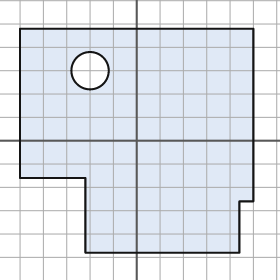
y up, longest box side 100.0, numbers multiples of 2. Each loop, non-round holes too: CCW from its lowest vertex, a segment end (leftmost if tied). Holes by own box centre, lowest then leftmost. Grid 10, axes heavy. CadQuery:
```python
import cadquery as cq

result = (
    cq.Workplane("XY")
    .moveTo(-22.0, -48.0)
    .lineTo(44.0, -48.0)
    .lineTo(44.0, -26.0)
    .lineTo(50.0, -26.0)
    .lineTo(50.0, 48.0)
    .lineTo(-50.0, 48.0)
    .lineTo(-50.0, -16.0)
    .lineTo(-22.0, -16.0)
    .close()
    .moveTo(-20.0, 30.0)
    .circle(8.0)
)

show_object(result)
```